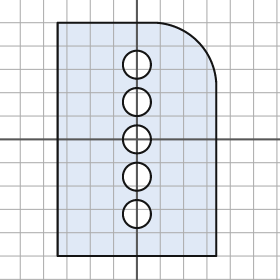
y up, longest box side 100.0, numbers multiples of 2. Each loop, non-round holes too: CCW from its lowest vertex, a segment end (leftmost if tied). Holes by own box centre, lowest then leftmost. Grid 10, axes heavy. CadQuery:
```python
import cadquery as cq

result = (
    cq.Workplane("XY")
    .moveTo(-34.0, -50.0)
    .lineTo(34.0, -50.0)
    .lineTo(34.0, 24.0)
    .threePointArc((26.0, 42.0), (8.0, 50.0))
    .lineTo(-34.0, 50.0)
    .close()
    .moveTo(0.0, -32.0)
    .circle(6.0)
    .moveTo(0.0, -16.0)
    .circle(6.0)
    .moveTo(0.0, 0.0)
    .circle(6.0)
    .moveTo(0.0, 16.0)
    .circle(6.0)
    .moveTo(0.0, 32.0)
    .circle(6.0)
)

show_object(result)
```